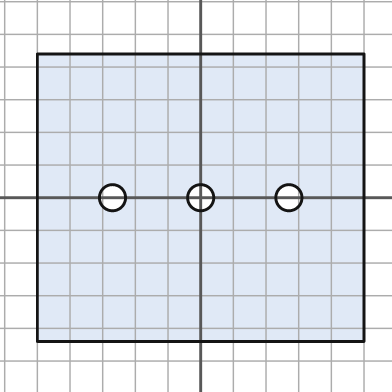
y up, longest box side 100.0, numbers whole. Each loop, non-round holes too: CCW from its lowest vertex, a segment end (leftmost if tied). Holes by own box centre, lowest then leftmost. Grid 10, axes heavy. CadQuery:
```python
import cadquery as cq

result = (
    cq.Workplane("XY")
    .moveTo(-50.0, -44.0)
    .lineTo(50.0, -44.0)
    .lineTo(50.0, 44.0)
    .lineTo(-50.0, 44.0)
    .close()
    .moveTo(-27.0, 0.0)
    .circle(4.0)
    .moveTo(0.0, 0.0)
    .circle(4.0)
    .moveTo(27.0, 0.0)
    .circle(4.0)
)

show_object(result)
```